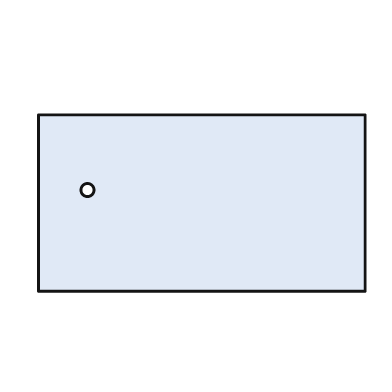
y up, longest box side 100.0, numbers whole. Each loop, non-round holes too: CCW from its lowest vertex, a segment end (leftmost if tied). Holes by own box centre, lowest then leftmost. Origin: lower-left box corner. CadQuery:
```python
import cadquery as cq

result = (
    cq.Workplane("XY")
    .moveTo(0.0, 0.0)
    .lineTo(100.0, 0.0)
    .lineTo(100.0, 54.0)
    .lineTo(0.0, 54.0)
    .close()
    .moveTo(15.0, 31.0)
    .circle(2.0)
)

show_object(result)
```